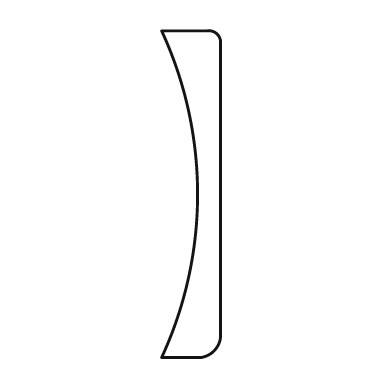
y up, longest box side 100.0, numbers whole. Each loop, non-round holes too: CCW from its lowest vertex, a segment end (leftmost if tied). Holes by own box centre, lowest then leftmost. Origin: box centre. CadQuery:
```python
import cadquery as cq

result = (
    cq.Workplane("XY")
    .moveTo(-9.0, -50.0)
    .lineTo(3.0, -50.0)
    .threePointArc((7.0, -48.0), (9.0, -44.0))
    .lineTo(9.0, 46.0)
    .threePointArc((8.0, 49.0), (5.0, 50.0))
    .lineTo(-9.0, 50.0)
    .threePointArc((2.0, 0.0), (-9.0, -50.0))
    .close()
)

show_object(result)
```